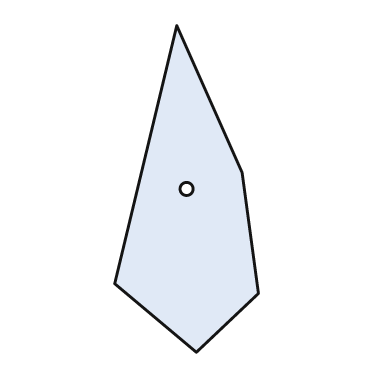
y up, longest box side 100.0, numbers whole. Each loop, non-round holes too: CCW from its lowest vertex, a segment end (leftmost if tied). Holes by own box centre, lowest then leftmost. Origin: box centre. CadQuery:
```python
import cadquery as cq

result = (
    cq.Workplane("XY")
    .moveTo(3.0, -50.0)
    .lineTo(22.0, -32.0)
    .lineTo(17.0, 5.0)
    .lineTo(-3.0, 50.0)
    .lineTo(-22.0, -29.0)
    .close()
    .moveTo(0.0, 0.0)
    .circle(2.0)
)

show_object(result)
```